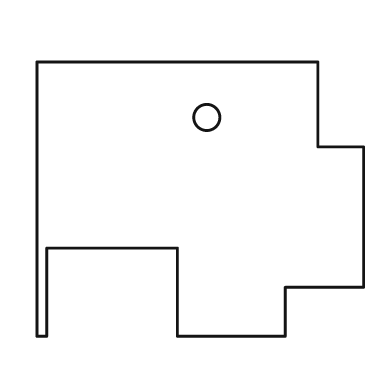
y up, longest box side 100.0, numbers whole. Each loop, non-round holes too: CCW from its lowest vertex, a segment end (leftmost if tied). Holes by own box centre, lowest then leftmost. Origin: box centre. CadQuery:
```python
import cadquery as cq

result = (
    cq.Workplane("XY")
    .moveTo(-50.0, -42.0)
    .lineTo(-47.0, -42.0)
    .lineTo(-47.0, -15.0)
    .lineTo(-7.0, -15.0)
    .lineTo(-7.0, -42.0)
    .lineTo(26.0, -42.0)
    .lineTo(26.0, -27.0)
    .lineTo(50.0, -27.0)
    .lineTo(50.0, 16.0)
    .lineTo(36.0, 16.0)
    .lineTo(36.0, 42.0)
    .lineTo(-50.0, 42.0)
    .close()
    .moveTo(2.0, 25.0)
    .circle(4.0)
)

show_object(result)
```